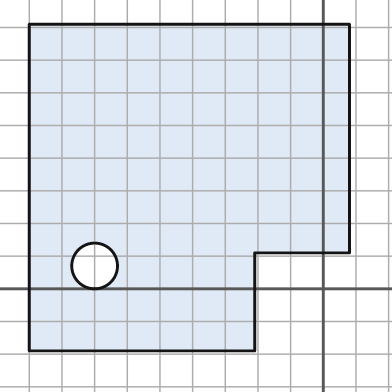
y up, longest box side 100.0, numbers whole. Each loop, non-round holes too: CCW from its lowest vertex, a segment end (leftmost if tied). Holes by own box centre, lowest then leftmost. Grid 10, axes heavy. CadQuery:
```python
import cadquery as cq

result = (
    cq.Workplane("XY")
    .moveTo(-90.0, -19.0)
    .lineTo(-21.0, -19.0)
    .lineTo(-21.0, 11.0)
    .lineTo(8.0, 11.0)
    .lineTo(8.0, 81.0)
    .lineTo(-90.0, 81.0)
    .close()
    .moveTo(-70.0, 7.0)
    .circle(7.0)
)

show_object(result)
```